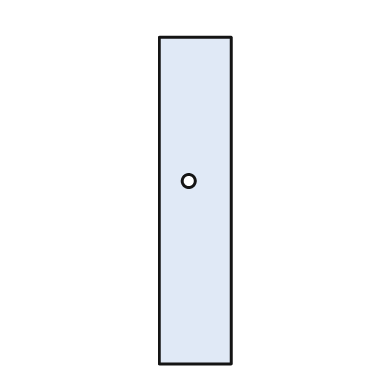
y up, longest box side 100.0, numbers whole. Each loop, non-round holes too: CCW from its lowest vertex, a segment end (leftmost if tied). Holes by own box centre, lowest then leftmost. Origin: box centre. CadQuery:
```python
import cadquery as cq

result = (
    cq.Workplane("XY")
    .moveTo(-11.0, -50.0)
    .lineTo(11.0, -50.0)
    .lineTo(11.0, 50.0)
    .lineTo(-11.0, 50.0)
    .close()
    .moveTo(-2.0, 6.0)
    .circle(2.0)
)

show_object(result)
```